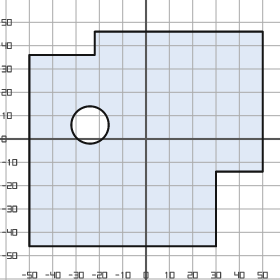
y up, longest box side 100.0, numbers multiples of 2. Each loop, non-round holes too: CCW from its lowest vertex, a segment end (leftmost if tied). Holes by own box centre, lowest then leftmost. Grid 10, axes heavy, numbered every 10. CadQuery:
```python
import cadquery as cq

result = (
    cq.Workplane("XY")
    .moveTo(-50.0, -46.0)
    .lineTo(30.0, -46.0)
    .lineTo(30.0, -14.0)
    .lineTo(50.0, -14.0)
    .lineTo(50.0, 46.0)
    .lineTo(-22.0, 46.0)
    .lineTo(-22.0, 36.0)
    .lineTo(-50.0, 36.0)
    .close()
    .moveTo(-24.0, 6.0)
    .circle(8.0)
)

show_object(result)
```